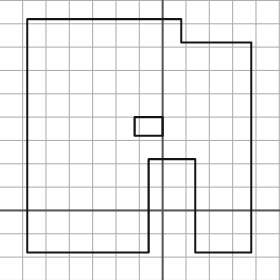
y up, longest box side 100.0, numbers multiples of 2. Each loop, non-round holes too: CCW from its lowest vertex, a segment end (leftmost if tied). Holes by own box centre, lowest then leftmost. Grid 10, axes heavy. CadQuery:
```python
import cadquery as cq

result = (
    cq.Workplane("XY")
    .moveTo(-58.0, -18.0)
    .lineTo(-6.0, -18.0)
    .lineTo(-6.0, 22.0)
    .lineTo(14.0, 22.0)
    .lineTo(14.0, -18.0)
    .lineTo(38.0, -18.0)
    .lineTo(38.0, 72.0)
    .lineTo(8.0, 72.0)
    .lineTo(8.0, 82.0)
    .lineTo(-58.0, 82.0)
    .close()
    .moveTo(-12.0, 32.0)
    .lineTo(0.0, 32.0)
    .lineTo(0.0, 40.0)
    .lineTo(-12.0, 40.0)
    .close()
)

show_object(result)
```